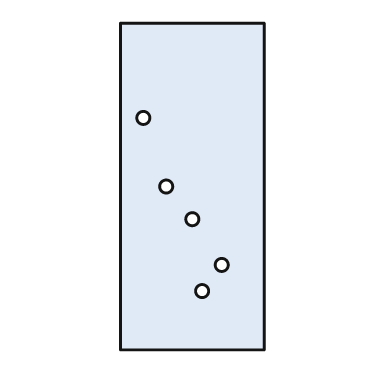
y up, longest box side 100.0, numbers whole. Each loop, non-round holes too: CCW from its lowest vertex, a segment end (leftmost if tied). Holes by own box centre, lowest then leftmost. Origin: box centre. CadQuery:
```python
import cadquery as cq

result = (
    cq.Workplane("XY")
    .moveTo(-22.0, -50.0)
    .lineTo(22.0, -50.0)
    .lineTo(22.0, 50.0)
    .lineTo(-22.0, 50.0)
    .close()
    .moveTo(3.0, -32.0)
    .circle(2.0)
    .moveTo(9.0, -24.0)
    .circle(2.0)
    .moveTo(0.0, -10.0)
    .circle(2.0)
    .moveTo(-8.0, 0.0)
    .circle(2.0)
    .moveTo(-15.0, 21.0)
    .circle(2.0)
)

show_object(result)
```